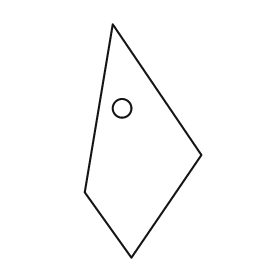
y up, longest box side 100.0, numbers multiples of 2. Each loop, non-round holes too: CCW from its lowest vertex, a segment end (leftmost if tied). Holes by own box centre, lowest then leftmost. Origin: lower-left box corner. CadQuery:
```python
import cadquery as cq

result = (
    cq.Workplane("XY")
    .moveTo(20.0, 0.0)
    .lineTo(50.0, 44.0)
    .lineTo(12.0, 100.0)
    .lineTo(0.0, 28.0)
    .close()
    .moveTo(16.0, 64.0)
    .circle(4.0)
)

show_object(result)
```